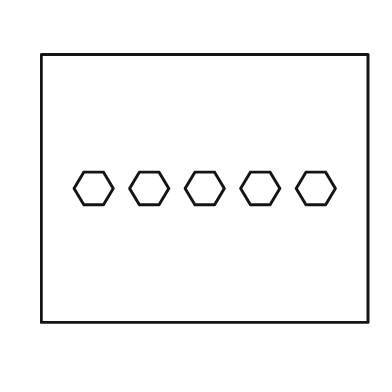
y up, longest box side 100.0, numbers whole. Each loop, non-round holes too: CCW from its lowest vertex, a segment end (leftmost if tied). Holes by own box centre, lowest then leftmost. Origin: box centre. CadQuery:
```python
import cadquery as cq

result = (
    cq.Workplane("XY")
    .moveTo(-50.0, -41.0)
    .lineTo(50.0, -41.0)
    .lineTo(50.0, 41.0)
    .lineTo(-50.0, 41.0)
    .close()
    .moveTo(-37.0, -5.0)
    .lineTo(-31.0, -5.0)
    .lineTo(-28.0, 0.0)
    .lineTo(-31.0, 5.0)
    .lineTo(-37.0, 5.0)
    .lineTo(-40.0, 0.0)
    .close()
    .moveTo(-20.0, -5.0)
    .lineTo(-14.0, -5.0)
    .lineTo(-11.0, 0.0)
    .lineTo(-14.0, 5.0)
    .lineTo(-20.0, 5.0)
    .lineTo(-23.0, 0.0)
    .close()
    .moveTo(-3.0, -5.0)
    .lineTo(3.0, -5.0)
    .lineTo(6.0, 0.0)
    .lineTo(3.0, 5.0)
    .lineTo(-3.0, 5.0)
    .lineTo(-6.0, 0.0)
    .close()
    .moveTo(14.0, -5.0)
    .lineTo(20.0, -5.0)
    .lineTo(23.0, 0.0)
    .lineTo(20.0, 5.0)
    .lineTo(14.0, 5.0)
    .lineTo(11.0, 0.0)
    .close()
    .moveTo(31.0, -5.0)
    .lineTo(37.0, -5.0)
    .lineTo(40.0, 0.0)
    .lineTo(37.0, 5.0)
    .lineTo(31.0, 5.0)
    .lineTo(28.0, 0.0)
    .close()
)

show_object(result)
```